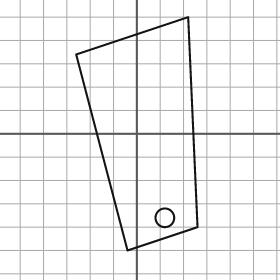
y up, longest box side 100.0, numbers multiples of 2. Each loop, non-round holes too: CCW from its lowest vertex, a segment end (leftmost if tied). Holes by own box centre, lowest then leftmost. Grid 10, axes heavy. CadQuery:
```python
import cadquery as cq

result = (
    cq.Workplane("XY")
    .moveTo(-4.0, -50.0)
    .lineTo(26.0, -40.0)
    .lineTo(22.0, 50.0)
    .lineTo(-26.0, 34.0)
    .close()
    .moveTo(12.0, -36.0)
    .circle(4.0)
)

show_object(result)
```